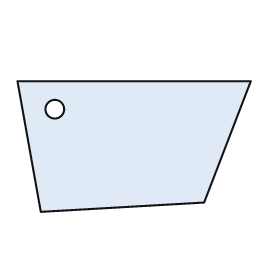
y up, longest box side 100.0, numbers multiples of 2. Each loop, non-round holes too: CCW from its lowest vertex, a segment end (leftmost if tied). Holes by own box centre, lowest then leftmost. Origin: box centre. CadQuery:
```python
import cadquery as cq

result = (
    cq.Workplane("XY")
    .moveTo(-40.0, -28.0)
    .lineTo(30.0, -24.0)
    .lineTo(50.0, 28.0)
    .lineTo(-50.0, 28.0)
    .close()
    .moveTo(-34.0, 16.0)
    .circle(4.0)
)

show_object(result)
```